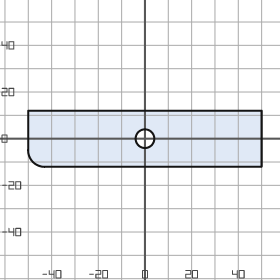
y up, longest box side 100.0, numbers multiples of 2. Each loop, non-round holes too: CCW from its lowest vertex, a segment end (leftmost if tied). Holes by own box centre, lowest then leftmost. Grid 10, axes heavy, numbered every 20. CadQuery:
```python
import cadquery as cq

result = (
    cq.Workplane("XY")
    .moveTo(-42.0, -12.0)
    .lineTo(50.0, -12.0)
    .lineTo(50.0, 12.0)
    .lineTo(-50.0, 12.0)
    .lineTo(-50.0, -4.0)
    .threePointArc((-48.0, -10.0), (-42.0, -12.0))
    .close()
    .moveTo(0.0, 0.0)
    .circle(4.0)
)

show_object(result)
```